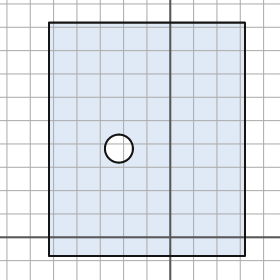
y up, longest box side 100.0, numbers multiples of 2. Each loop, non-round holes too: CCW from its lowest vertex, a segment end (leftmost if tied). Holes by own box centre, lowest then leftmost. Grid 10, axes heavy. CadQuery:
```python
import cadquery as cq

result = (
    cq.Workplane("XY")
    .moveTo(-52.0, -8.0)
    .lineTo(32.0, -8.0)
    .lineTo(32.0, 92.0)
    .lineTo(-52.0, 92.0)
    .close()
    .moveTo(-22.0, 38.0)
    .circle(6.0)
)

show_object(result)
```